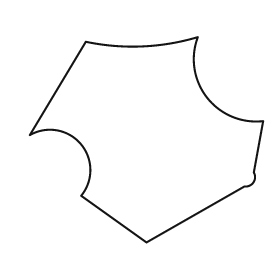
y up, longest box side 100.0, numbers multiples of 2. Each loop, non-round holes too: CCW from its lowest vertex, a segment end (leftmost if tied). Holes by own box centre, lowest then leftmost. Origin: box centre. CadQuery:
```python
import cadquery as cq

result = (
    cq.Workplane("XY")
    .moveTo(0.0, -44.0)
    .lineTo(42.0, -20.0)
    .threePointArc((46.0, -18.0), (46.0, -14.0))
    .lineTo(50.0, 8.0)
    .threePointArc((26.0, 18.0), (22.0, 44.0))
    .threePointArc((-2.0, 40.0), (-26.0, 42.0))
    .lineTo(-50.0, 2.0)
    .threePointArc((-28.0, -2.0), (-28.0, -24.0))
    .close()
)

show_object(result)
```